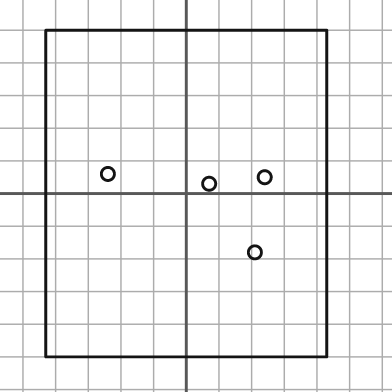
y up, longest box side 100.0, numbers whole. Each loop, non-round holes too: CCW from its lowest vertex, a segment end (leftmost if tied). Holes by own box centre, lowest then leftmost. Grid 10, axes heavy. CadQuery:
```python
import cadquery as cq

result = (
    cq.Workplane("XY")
    .moveTo(-43.0, -50.0)
    .lineTo(43.0, -50.0)
    .lineTo(43.0, 50.0)
    .lineTo(-43.0, 50.0)
    .close()
    .moveTo(21.0, -18.0)
    .circle(2.0)
    .moveTo(7.0, 3.0)
    .circle(2.0)
    .moveTo(24.0, 5.0)
    .circle(2.0)
    .moveTo(-24.0, 6.0)
    .circle(2.0)
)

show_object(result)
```